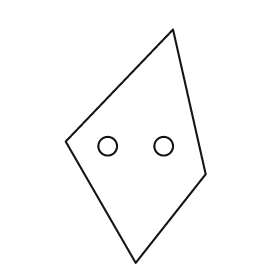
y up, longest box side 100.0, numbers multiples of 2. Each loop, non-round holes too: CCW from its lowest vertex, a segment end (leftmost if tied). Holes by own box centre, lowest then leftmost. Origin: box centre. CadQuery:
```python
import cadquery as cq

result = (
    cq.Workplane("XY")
    .moveTo(0.0, -50.0)
    .lineTo(30.0, -12.0)
    .lineTo(16.0, 50.0)
    .lineTo(-30.0, 2.0)
    .close()
    .moveTo(-12.0, 0.0)
    .circle(4.0)
    .moveTo(12.0, 0.0)
    .circle(4.0)
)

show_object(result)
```